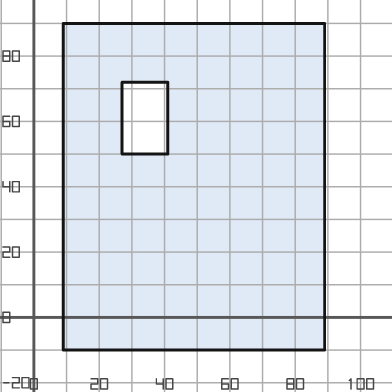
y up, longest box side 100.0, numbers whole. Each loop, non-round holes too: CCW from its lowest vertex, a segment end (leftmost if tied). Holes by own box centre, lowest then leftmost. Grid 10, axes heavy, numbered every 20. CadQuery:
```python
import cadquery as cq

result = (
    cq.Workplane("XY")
    .moveTo(9.0, -10.0)
    .lineTo(89.0, -10.0)
    .lineTo(89.0, 90.0)
    .lineTo(9.0, 90.0)
    .close()
    .moveTo(27.0, 50.0)
    .lineTo(41.0, 50.0)
    .lineTo(41.0, 72.0)
    .lineTo(27.0, 72.0)
    .close()
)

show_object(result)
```